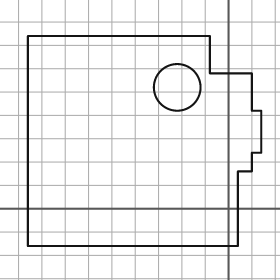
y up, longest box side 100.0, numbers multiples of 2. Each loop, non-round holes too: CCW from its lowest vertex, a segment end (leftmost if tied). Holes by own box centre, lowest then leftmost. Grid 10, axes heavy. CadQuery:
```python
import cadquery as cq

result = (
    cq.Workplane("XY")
    .moveTo(-86.0, -16.0)
    .lineTo(4.0, -16.0)
    .lineTo(4.0, 16.0)
    .lineTo(10.0, 16.0)
    .lineTo(10.0, 24.0)
    .lineTo(14.0, 24.0)
    .lineTo(14.0, 42.0)
    .lineTo(10.0, 42.0)
    .lineTo(10.0, 58.0)
    .lineTo(-8.0, 58.0)
    .lineTo(-8.0, 74.0)
    .lineTo(-86.0, 74.0)
    .close()
    .moveTo(-22.0, 52.0)
    .circle(10.0)
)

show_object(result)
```